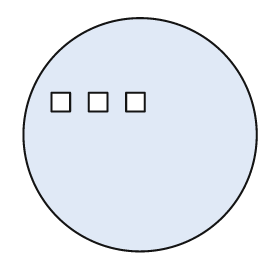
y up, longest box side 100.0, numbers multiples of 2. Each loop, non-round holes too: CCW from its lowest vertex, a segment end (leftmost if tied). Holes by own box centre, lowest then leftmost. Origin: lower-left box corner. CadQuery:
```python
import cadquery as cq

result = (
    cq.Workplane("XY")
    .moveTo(50.0, 50.0)
    .circle(50.0)
    .moveTo(12.0, 60.0)
    .lineTo(20.0, 60.0)
    .lineTo(20.0, 68.0)
    .lineTo(12.0, 68.0)
    .close()
    .moveTo(28.0, 60.0)
    .lineTo(36.0, 60.0)
    .lineTo(36.0, 68.0)
    .lineTo(28.0, 68.0)
    .close()
    .moveTo(44.0, 60.0)
    .lineTo(52.0, 60.0)
    .lineTo(52.0, 68.0)
    .lineTo(44.0, 68.0)
    .close()
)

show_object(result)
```